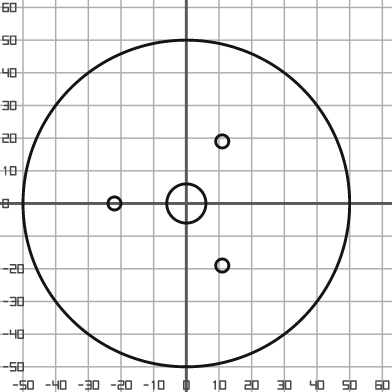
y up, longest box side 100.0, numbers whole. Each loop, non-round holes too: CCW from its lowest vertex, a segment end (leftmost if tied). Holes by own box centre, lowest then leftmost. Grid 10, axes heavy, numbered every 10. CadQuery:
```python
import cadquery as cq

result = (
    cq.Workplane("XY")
    .moveTo(0.0, 0.0)
    .circle(50.0)
    .moveTo(11.0, -19.0)
    .circle(2.0)
    .moveTo(-22.0, 0.0)
    .circle(2.0)
    .moveTo(0.0, 0.0)
    .circle(6.0)
    .moveTo(11.0, 19.0)
    .circle(2.0)
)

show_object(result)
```